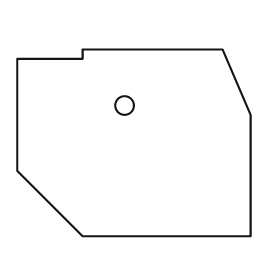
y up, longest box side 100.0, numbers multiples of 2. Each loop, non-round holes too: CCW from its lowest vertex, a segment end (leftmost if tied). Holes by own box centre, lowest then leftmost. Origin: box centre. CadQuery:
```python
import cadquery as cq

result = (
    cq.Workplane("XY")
    .moveTo(-22.0, -40.0)
    .lineTo(50.0, -40.0)
    .lineTo(50.0, 12.0)
    .lineTo(38.0, 40.0)
    .lineTo(-22.0, 40.0)
    .lineTo(-22.0, 36.0)
    .lineTo(-50.0, 36.0)
    .lineTo(-50.0, -12.0)
    .close()
    .moveTo(-4.0, 16.0)
    .circle(4.0)
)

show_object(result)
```